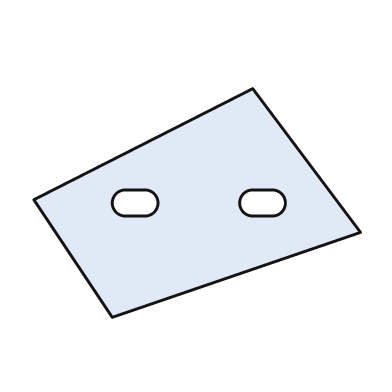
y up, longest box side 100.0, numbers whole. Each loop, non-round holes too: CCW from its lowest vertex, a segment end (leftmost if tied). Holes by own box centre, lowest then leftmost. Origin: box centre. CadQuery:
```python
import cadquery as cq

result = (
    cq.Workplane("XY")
    .moveTo(-26.0, -35.0)
    .lineTo(50.0, -9.0)
    .lineTo(17.0, 35.0)
    .lineTo(-50.0, 1.0)
    .close()
    .moveTo(-22.0, -4.0)
    .lineTo(-16.0, -4.0)
    .threePointArc((-12.0, 0.0), (-16.0, 4.0))
    .lineTo(-22.0, 4.0)
    .threePointArc((-26.0, 0.0), (-22.0, -4.0))
    .close()
    .moveTo(17.0, -4.0)
    .lineTo(23.0, -4.0)
    .threePointArc((27.0, 0.0), (23.0, 4.0))
    .lineTo(17.0, 4.0)
    .threePointArc((13.0, 0.0), (17.0, -4.0))
    .close()
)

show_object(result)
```